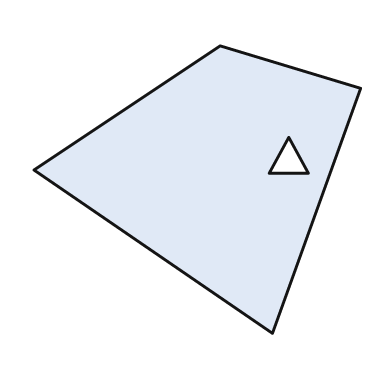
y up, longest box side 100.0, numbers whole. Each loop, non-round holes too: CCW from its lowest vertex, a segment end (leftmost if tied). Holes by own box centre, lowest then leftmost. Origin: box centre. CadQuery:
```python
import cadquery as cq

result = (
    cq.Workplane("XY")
    .moveTo(23.0, -44.0)
    .lineTo(50.0, 31.0)
    .lineTo(7.0, 44.0)
    .lineTo(-50.0, 6.0)
    .close()
    .moveTo(22.0, 5.0)
    .lineTo(34.0, 5.0)
    .lineTo(28.0, 16.0)
    .close()
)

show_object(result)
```